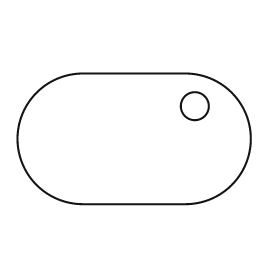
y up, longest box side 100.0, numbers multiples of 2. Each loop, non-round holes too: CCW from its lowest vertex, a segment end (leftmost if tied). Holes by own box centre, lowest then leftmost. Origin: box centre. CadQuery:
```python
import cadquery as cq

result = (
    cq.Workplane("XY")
    .moveTo(-22.0, -28.0)
    .lineTo(22.0, -28.0)
    .threePointArc((50.0, 0.0), (22.0, 28.0))
    .lineTo(-22.0, 28.0)
    .threePointArc((-50.0, 0.0), (-22.0, -28.0))
    .close()
    .moveTo(26.0, 14.0)
    .circle(6.0)
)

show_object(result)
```